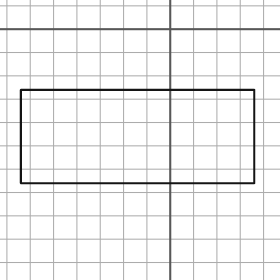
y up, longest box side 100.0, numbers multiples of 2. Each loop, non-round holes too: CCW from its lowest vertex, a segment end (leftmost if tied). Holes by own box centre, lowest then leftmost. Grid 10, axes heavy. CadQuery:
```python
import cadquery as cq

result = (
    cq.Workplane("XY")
    .moveTo(-64.0, -66.0)
    .lineTo(36.0, -66.0)
    .lineTo(36.0, -26.0)
    .lineTo(-64.0, -26.0)
    .close()
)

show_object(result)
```